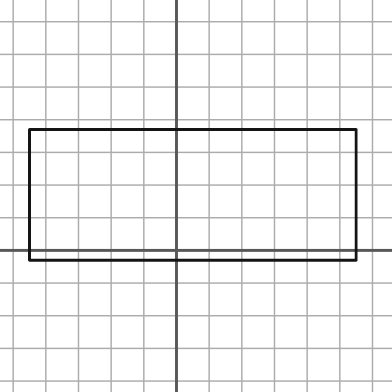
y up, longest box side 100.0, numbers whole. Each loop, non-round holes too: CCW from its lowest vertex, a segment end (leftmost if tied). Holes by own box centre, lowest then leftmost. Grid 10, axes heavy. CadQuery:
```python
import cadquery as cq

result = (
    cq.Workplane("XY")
    .moveTo(-45.0, -3.0)
    .lineTo(55.0, -3.0)
    .lineTo(55.0, 37.0)
    .lineTo(-45.0, 37.0)
    .close()
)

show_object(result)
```